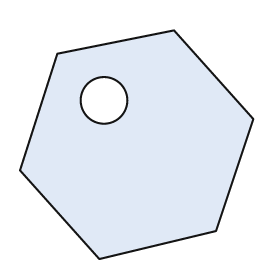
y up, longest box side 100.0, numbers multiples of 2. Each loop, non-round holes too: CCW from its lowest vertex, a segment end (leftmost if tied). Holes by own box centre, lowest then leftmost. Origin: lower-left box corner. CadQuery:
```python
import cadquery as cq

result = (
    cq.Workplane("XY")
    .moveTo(34.0, 0.0)
    .lineTo(84.0, 12.0)
    .lineTo(100.0, 60.0)
    .lineTo(66.0, 98.0)
    .lineTo(16.0, 88.0)
    .lineTo(0.0, 38.0)
    .close()
    .moveTo(36.0, 68.0)
    .circle(10.0)
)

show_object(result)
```